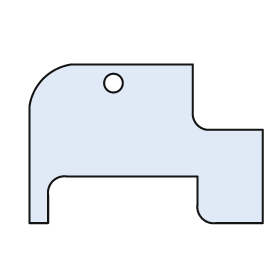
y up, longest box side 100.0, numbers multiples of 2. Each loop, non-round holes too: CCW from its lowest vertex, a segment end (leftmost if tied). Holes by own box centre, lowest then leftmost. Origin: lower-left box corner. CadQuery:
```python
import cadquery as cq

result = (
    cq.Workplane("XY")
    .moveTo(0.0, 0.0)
    .lineTo(8.0, 0.0)
    .lineTo(8.0, 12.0)
    .threePointArc((10.0, 18.0), (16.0, 20.0))
    .lineTo(72.0, 20.0)
    .lineTo(72.0, 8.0)
    .threePointArc((74.0, 2.0), (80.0, 0.0))
    .lineTo(100.0, 0.0)
    .lineTo(100.0, 40.0)
    .lineTo(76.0, 40.0)
    .threePointArc((72.0, 42.0), (70.0, 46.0))
    .lineTo(70.0, 68.0)
    .lineTo(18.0, 68.0)
    .threePointArc((6.0, 62.0), (0.0, 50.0))
    .close()
    .moveTo(36.0, 60.0)
    .circle(4.0)
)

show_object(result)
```